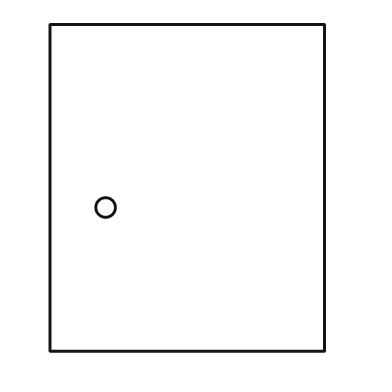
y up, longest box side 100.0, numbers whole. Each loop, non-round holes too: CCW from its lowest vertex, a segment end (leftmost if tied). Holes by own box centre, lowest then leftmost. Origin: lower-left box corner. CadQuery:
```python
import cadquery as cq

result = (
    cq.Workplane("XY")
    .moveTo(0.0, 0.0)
    .lineTo(84.0, 0.0)
    .lineTo(84.0, 100.0)
    .lineTo(0.0, 100.0)
    .close()
    .moveTo(17.0, 44.0)
    .circle(3.0)
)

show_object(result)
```